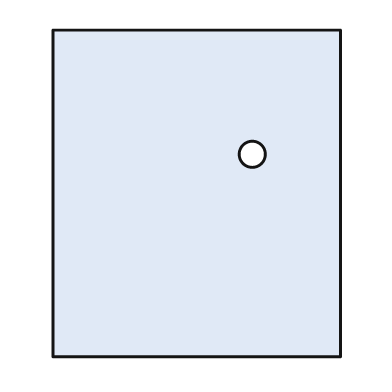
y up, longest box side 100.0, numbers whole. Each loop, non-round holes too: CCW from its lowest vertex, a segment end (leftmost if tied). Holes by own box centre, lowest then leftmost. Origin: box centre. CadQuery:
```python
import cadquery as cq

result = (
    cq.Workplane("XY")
    .moveTo(-44.0, -50.0)
    .lineTo(44.0, -50.0)
    .lineTo(44.0, 50.0)
    .lineTo(-44.0, 50.0)
    .close()
    .moveTo(17.0, 12.0)
    .circle(4.0)
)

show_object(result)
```